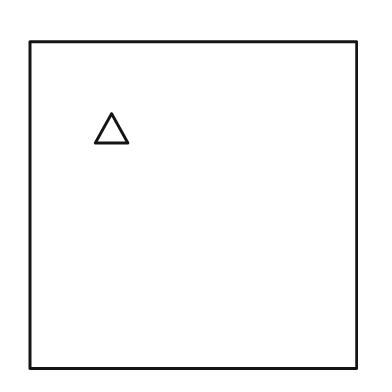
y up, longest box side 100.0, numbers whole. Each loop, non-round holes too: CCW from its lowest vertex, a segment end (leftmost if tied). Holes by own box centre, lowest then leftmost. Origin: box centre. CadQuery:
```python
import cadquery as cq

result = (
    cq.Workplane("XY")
    .moveTo(-50.0, -50.0)
    .lineTo(50.0, -50.0)
    .lineTo(50.0, 50.0)
    .lineTo(-50.0, 50.0)
    .close()
    .moveTo(-30.0, 19.0)
    .lineTo(-20.0, 19.0)
    .lineTo(-25.0, 28.0)
    .close()
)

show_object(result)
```